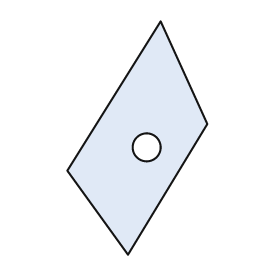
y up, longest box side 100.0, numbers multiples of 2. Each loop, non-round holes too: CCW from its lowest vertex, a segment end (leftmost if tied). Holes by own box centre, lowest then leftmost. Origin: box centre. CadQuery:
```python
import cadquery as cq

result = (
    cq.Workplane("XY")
    .moveTo(-4.0, -50.0)
    .lineTo(30.0, 6.0)
    .lineTo(10.0, 50.0)
    .lineTo(-30.0, -14.0)
    .close()
    .moveTo(4.0, -4.0)
    .circle(6.0)
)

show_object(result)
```